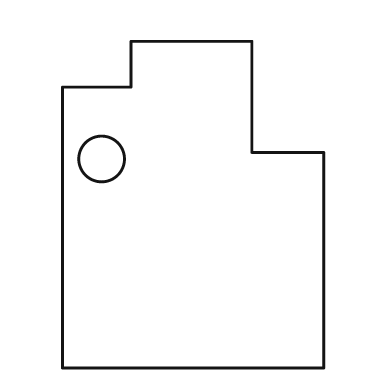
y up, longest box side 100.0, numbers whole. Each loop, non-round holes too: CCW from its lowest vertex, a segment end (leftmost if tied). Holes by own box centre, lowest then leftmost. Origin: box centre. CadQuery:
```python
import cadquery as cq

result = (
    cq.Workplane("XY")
    .moveTo(-40.0, -50.0)
    .lineTo(40.0, -50.0)
    .lineTo(40.0, 16.0)
    .lineTo(18.0, 16.0)
    .lineTo(18.0, 50.0)
    .lineTo(-19.0, 50.0)
    .lineTo(-19.0, 36.0)
    .lineTo(-40.0, 36.0)
    .close()
    .moveTo(-28.0, 14.0)
    .circle(7.0)
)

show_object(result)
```